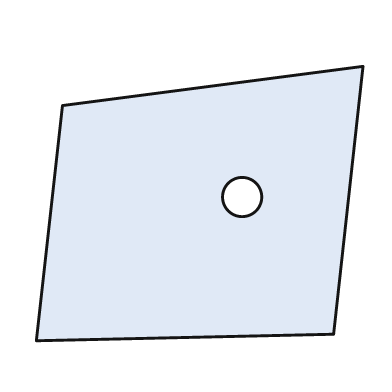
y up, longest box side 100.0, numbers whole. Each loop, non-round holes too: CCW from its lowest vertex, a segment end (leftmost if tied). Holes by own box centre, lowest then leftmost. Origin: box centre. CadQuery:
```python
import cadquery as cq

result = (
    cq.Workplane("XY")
    .moveTo(-50.0, -42.0)
    .lineTo(41.0, -40.0)
    .lineTo(50.0, 42.0)
    .lineTo(-42.0, 30.0)
    .close()
    .moveTo(13.0, 2.0)
    .circle(6.0)
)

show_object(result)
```